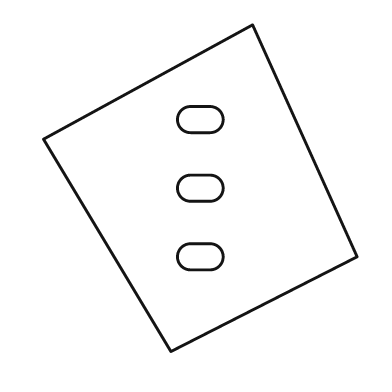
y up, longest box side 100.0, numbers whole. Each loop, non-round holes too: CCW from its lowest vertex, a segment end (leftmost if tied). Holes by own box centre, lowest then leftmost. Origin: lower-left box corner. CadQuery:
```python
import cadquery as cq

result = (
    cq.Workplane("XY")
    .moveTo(39.0, 0.0)
    .lineTo(96.0, 29.0)
    .lineTo(64.0, 100.0)
    .lineTo(0.0, 65.0)
    .close()
    .moveTo(45.0, 25.0)
    .lineTo(51.0, 25.0)
    .threePointArc((55.0, 29.0), (51.0, 33.0))
    .lineTo(45.0, 33.0)
    .threePointArc((41.0, 29.0), (45.0, 25.0))
    .close()
    .moveTo(45.0, 46.0)
    .lineTo(51.0, 46.0)
    .threePointArc((55.0, 50.0), (51.0, 54.0))
    .lineTo(45.0, 54.0)
    .threePointArc((41.0, 50.0), (45.0, 46.0))
    .close()
    .moveTo(45.0, 67.0)
    .lineTo(51.0, 67.0)
    .threePointArc((55.0, 71.0), (51.0, 75.0))
    .lineTo(45.0, 75.0)
    .threePointArc((41.0, 71.0), (45.0, 67.0))
    .close()
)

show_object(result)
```